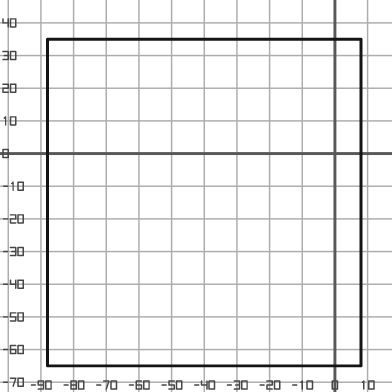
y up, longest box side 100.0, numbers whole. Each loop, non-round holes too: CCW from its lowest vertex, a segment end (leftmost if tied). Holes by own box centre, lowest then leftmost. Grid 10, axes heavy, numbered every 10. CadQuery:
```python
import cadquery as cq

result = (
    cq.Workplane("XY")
    .moveTo(-88.0, -65.0)
    .lineTo(8.0, -65.0)
    .lineTo(8.0, 35.0)
    .lineTo(-88.0, 35.0)
    .close()
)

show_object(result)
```